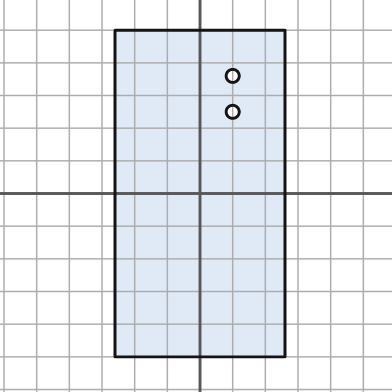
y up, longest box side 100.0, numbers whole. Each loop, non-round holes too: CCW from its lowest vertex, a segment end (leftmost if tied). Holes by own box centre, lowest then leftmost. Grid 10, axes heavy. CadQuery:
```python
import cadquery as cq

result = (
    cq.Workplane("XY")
    .moveTo(-26.0, -50.0)
    .lineTo(26.0, -50.0)
    .lineTo(26.0, 50.0)
    .lineTo(-26.0, 50.0)
    .close()
    .moveTo(10.0, 25.0)
    .circle(2.0)
    .moveTo(10.0, 36.0)
    .circle(2.0)
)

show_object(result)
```